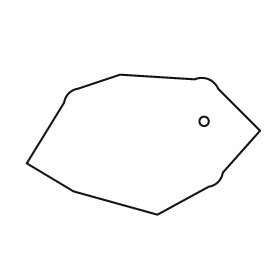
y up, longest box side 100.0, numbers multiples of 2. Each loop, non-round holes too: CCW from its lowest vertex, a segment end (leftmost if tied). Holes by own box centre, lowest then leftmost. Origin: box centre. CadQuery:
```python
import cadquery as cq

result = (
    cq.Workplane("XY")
    .moveTo(6.0, -30.0)
    .lineTo(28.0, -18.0)
    .threePointArc((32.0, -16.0), (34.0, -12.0))
    .lineTo(50.0, 6.0)
    .lineTo(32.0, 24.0)
    .threePointArc((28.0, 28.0), (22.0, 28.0))
    .lineTo(-10.0, 30.0)
    .lineTo(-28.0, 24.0)
    .threePointArc((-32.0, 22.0), (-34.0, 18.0))
    .lineTo(-50.0, -8.0)
    .lineTo(-30.0, -20.0)
    .close()
    .moveTo(26.0, 10.0)
    .circle(2.0)
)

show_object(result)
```